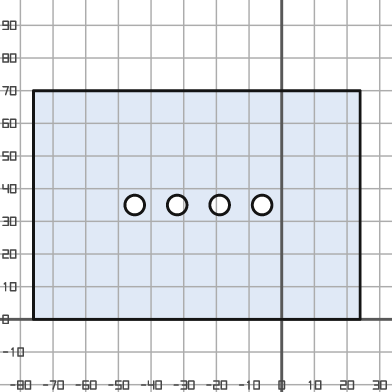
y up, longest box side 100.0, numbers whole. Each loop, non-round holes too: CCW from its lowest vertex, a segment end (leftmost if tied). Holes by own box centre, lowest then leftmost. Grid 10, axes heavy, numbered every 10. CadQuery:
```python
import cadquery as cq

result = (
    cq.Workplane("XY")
    .moveTo(-76.0, 0.0)
    .lineTo(24.0, 0.0)
    .lineTo(24.0, 70.0)
    .lineTo(-76.0, 70.0)
    .close()
    .moveTo(-45.0, 35.0)
    .circle(3.0)
    .moveTo(-32.0, 35.0)
    .circle(3.0)
    .moveTo(-19.0, 35.0)
    .circle(3.0)
    .moveTo(-6.0, 35.0)
    .circle(3.0)
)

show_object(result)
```